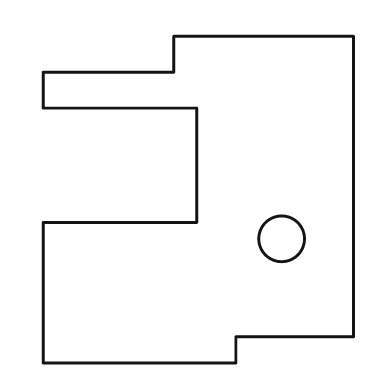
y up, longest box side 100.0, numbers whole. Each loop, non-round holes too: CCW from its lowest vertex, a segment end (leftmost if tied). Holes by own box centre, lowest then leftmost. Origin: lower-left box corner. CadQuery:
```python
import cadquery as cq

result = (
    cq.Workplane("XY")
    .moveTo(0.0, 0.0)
    .lineTo(59.0, 0.0)
    .lineTo(59.0, 8.0)
    .lineTo(95.0, 8.0)
    .lineTo(95.0, 100.0)
    .lineTo(40.0, 100.0)
    .lineTo(40.0, 89.0)
    .lineTo(0.0, 89.0)
    .lineTo(0.0, 78.0)
    .lineTo(47.0, 78.0)
    .lineTo(47.0, 43.0)
    .lineTo(0.0, 43.0)
    .close()
    .moveTo(73.0, 38.0)
    .circle(7.0)
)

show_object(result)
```